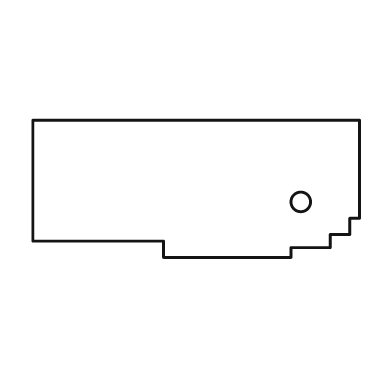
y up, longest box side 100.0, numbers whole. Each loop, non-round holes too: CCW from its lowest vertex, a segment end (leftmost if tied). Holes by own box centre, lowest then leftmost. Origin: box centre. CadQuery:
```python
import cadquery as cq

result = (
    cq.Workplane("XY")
    .moveTo(-10.0, -21.0)
    .lineTo(29.0, -21.0)
    .lineTo(29.0, -18.0)
    .lineTo(41.0, -18.0)
    .lineTo(41.0, -14.0)
    .lineTo(47.0, -14.0)
    .lineTo(47.0, -9.0)
    .lineTo(50.0, -9.0)
    .lineTo(50.0, 21.0)
    .lineTo(-50.0, 21.0)
    .lineTo(-50.0, -16.0)
    .lineTo(-10.0, -16.0)
    .close()
    .moveTo(32.0, -4.0)
    .circle(3.0)
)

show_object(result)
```